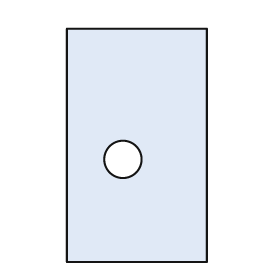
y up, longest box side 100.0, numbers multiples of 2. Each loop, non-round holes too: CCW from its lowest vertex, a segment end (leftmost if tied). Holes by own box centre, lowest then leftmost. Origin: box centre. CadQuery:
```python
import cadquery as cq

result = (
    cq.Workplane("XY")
    .moveTo(-30.0, -50.0)
    .lineTo(30.0, -50.0)
    .lineTo(30.0, 50.0)
    .lineTo(-30.0, 50.0)
    .close()
    .moveTo(-6.0, -6.0)
    .circle(8.0)
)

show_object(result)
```